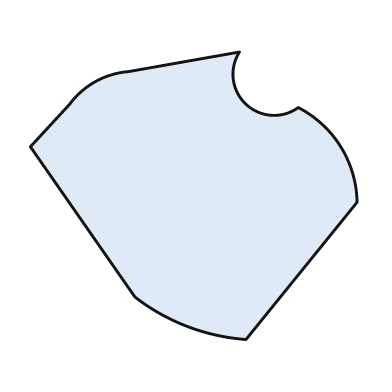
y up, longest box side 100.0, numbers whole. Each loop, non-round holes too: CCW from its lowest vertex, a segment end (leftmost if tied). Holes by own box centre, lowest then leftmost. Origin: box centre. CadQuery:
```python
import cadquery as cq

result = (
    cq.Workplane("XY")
    .moveTo(16.0, -44.0)
    .lineTo(50.0, -2.0)
    .threePointArc((45.0, 15.0), (32.0, 27.0))
    .threePointArc((16.0, 28.0), (14.0, 44.0))
    .lineTo(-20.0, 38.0)
    .threePointArc((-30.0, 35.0), (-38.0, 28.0))
    .lineTo(-50.0, 15.0)
    .lineTo(-18.0, -31.0)
    .threePointArc((-2.0, -40.0), (16.0, -44.0))
    .close()
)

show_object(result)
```